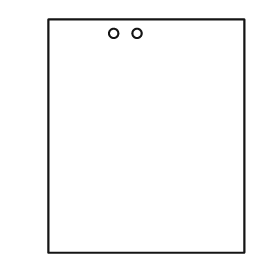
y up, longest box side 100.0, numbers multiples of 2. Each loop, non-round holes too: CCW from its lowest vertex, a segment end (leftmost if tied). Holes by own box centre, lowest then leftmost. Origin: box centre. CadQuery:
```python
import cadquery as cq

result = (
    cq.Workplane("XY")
    .moveTo(-42.0, -50.0)
    .lineTo(42.0, -50.0)
    .lineTo(42.0, 50.0)
    .lineTo(-42.0, 50.0)
    .close()
    .moveTo(-14.0, 44.0)
    .circle(2.0)
    .moveTo(-4.0, 44.0)
    .circle(2.0)
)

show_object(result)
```